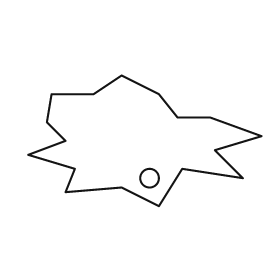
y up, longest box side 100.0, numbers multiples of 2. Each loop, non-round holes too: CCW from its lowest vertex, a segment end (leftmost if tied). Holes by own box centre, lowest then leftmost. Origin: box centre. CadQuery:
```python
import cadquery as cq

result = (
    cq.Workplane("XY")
    .moveTo(6.0, -28.0)
    .lineTo(16.0, -12.0)
    .lineTo(42.0, -16.0)
    .lineTo(30.0, -4.0)
    .lineTo(50.0, 2.0)
    .lineTo(28.0, 10.0)
    .lineTo(14.0, 10.0)
    .lineTo(6.0, 20.0)
    .lineTo(-10.0, 28.0)
    .lineTo(-22.0, 20.0)
    .lineTo(-40.0, 20.0)
    .lineTo(-42.0, 8.0)
    .lineTo(-34.0, 0.0)
    .lineTo(-50.0, -6.0)
    .lineTo(-30.0, -12.0)
    .lineTo(-34.0, -22.0)
    .lineTo(-10.0, -20.0)
    .close()
    .moveTo(2.0, -16.0)
    .circle(4.0)
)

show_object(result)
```